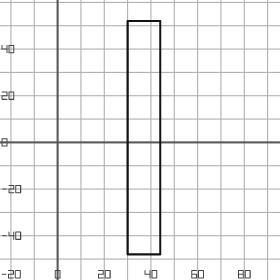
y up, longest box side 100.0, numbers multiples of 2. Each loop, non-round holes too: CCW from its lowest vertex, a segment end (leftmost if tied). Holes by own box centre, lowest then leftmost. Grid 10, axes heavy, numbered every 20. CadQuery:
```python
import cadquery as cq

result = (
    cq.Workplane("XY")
    .moveTo(30.0, -48.0)
    .lineTo(44.0, -48.0)
    .lineTo(44.0, 52.0)
    .lineTo(30.0, 52.0)
    .close()
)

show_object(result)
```